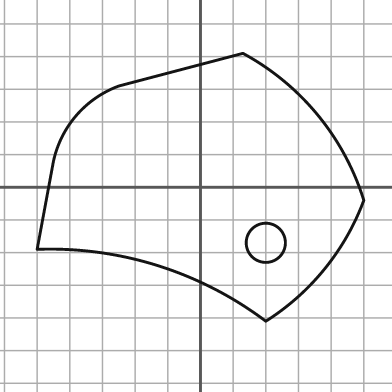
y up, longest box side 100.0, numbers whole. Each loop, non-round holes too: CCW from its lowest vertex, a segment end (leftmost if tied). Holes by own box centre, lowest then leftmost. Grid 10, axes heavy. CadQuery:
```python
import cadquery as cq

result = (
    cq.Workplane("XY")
    .moveTo(20.0, -41.0)
    .threePointArc((38.0, -25.0), (50.0, -4.0))
    .threePointArc((36.0, 22.0), (13.0, 41.0))
    .lineTo(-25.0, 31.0)
    .threePointArc((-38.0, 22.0), (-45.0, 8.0))
    .lineTo(-50.0, -19.0)
    .threePointArc((-13.0, -24.0), (20.0, -41.0))
    .close()
    .moveTo(20.0, -17.0)
    .circle(6.0)
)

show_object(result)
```